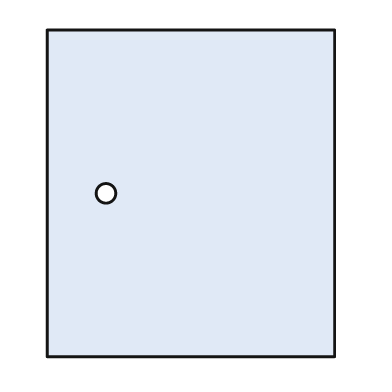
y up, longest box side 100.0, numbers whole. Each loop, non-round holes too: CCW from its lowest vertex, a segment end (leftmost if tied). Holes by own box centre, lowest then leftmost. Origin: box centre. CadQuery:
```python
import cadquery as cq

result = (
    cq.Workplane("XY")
    .moveTo(-44.0, -50.0)
    .lineTo(44.0, -50.0)
    .lineTo(44.0, 50.0)
    .lineTo(-44.0, 50.0)
    .close()
    .moveTo(-26.0, 0.0)
    .circle(3.0)
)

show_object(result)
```